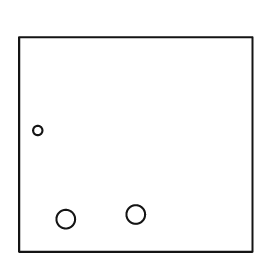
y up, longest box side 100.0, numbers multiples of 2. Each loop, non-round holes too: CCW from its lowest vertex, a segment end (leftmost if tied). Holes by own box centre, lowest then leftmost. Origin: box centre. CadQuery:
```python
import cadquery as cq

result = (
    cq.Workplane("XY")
    .moveTo(-50.0, -46.0)
    .lineTo(50.0, -46.0)
    .lineTo(50.0, 46.0)
    .lineTo(-50.0, 46.0)
    .close()
    .moveTo(-30.0, -32.0)
    .circle(4.0)
    .moveTo(0.0, -30.0)
    .circle(4.0)
    .moveTo(-42.0, 6.0)
    .circle(2.0)
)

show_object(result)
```